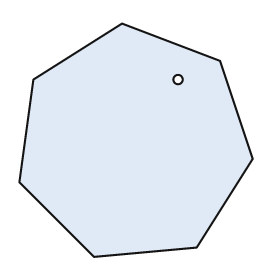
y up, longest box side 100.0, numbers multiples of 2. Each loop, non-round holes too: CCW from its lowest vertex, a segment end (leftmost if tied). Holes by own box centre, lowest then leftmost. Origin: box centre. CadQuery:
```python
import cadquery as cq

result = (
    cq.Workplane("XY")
    .moveTo(-18.0, -50.0)
    .lineTo(26.0, -46.0)
    .lineTo(50.0, -8.0)
    .lineTo(36.0, 34.0)
    .lineTo(-6.0, 50.0)
    .lineTo(-44.0, 26.0)
    .lineTo(-50.0, -18.0)
    .close()
    .moveTo(18.0, 26.0)
    .circle(2.0)
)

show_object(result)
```